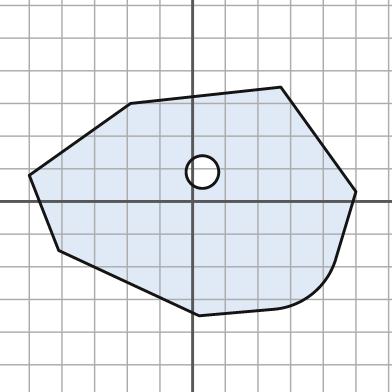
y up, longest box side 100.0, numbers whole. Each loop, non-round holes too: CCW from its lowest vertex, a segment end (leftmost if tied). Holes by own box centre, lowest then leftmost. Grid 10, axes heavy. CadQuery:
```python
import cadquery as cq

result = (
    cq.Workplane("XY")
    .moveTo(2.0, -35.0)
    .lineTo(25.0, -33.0)
    .threePointArc((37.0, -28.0), (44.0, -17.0))
    .lineTo(50.0, 3.0)
    .lineTo(27.0, 35.0)
    .lineTo(-19.0, 30.0)
    .lineTo(-50.0, 8.0)
    .lineTo(-41.0, -15.0)
    .close()
    .moveTo(3.0, 9.0)
    .circle(5.0)
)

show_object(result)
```